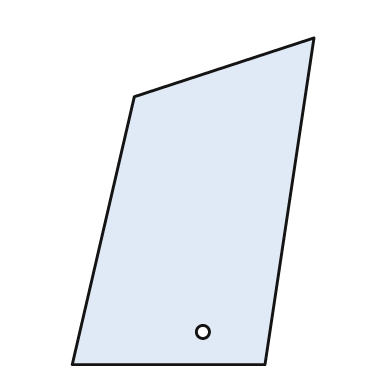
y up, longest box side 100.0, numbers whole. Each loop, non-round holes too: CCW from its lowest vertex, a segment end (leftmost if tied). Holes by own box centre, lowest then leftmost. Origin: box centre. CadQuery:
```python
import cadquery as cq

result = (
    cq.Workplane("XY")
    .moveTo(-37.0, -50.0)
    .lineTo(22.0, -50.0)
    .lineTo(37.0, 50.0)
    .lineTo(-18.0, 32.0)
    .close()
    .moveTo(3.0, -40.0)
    .circle(2.0)
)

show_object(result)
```